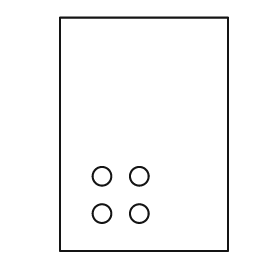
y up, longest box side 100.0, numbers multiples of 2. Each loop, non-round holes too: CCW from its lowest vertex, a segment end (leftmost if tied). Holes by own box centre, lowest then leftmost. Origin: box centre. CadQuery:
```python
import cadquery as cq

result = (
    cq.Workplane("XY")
    .moveTo(-36.0, -50.0)
    .lineTo(36.0, -50.0)
    .lineTo(36.0, 50.0)
    .lineTo(-36.0, 50.0)
    .close()
    .moveTo(-18.0, -34.0)
    .circle(4.0)
    .moveTo(-2.0, -34.0)
    .circle(4.0)
    .moveTo(-18.0, -18.0)
    .circle(4.0)
    .moveTo(-2.0, -18.0)
    .circle(4.0)
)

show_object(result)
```